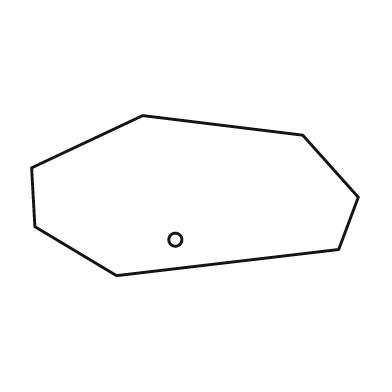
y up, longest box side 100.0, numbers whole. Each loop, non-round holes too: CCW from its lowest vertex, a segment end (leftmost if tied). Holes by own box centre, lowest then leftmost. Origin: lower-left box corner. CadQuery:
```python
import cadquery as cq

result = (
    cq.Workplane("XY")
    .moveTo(26.0, 0.0)
    .lineTo(94.0, 8.0)
    .lineTo(100.0, 24.0)
    .lineTo(83.0, 43.0)
    .lineTo(34.0, 49.0)
    .lineTo(0.0, 33.0)
    .lineTo(1.0, 15.0)
    .close()
    .moveTo(44.0, 11.0)
    .circle(2.0)
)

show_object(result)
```